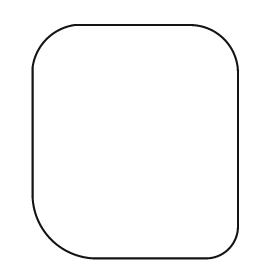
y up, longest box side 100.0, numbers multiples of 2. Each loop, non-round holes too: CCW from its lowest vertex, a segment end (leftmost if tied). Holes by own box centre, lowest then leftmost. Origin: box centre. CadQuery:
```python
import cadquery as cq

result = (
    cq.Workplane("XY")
    .moveTo(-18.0, -50.0)
    .lineTo(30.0, -50.0)
    .threePointArc((40.0, -46.0), (44.0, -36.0))
    .lineTo(44.0, 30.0)
    .threePointArc((38.0, 44.0), (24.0, 50.0))
    .lineTo(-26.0, 50.0)
    .threePointArc((-38.0, 44.0), (-44.0, 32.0))
    .lineTo(-44.0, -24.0)
    .threePointArc((-36.0, -42.0), (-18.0, -50.0))
    .close()
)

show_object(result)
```